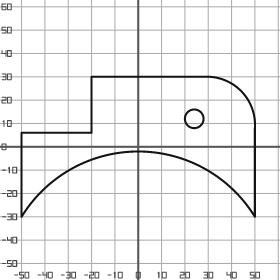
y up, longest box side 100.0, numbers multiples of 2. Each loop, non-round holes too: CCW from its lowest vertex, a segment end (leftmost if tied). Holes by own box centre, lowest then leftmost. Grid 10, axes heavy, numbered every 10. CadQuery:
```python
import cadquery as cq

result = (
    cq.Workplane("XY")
    .moveTo(-50.0, -30.0)
    .threePointArc((0.0, -2.0), (50.0, -30.0))
    .lineTo(50.0, 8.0)
    .threePointArc((44.0, 24.0), (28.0, 30.0))
    .lineTo(-20.0, 30.0)
    .lineTo(-20.0, 6.0)
    .lineTo(-50.0, 6.0)
    .close()
    .moveTo(24.0, 12.0)
    .circle(4.0)
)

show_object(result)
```